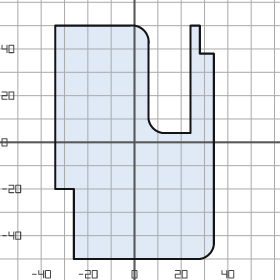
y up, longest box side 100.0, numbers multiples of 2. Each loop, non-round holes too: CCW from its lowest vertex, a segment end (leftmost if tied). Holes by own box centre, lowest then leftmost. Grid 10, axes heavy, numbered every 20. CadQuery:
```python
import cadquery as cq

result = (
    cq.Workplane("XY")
    .moveTo(-26.0, -50.0)
    .lineTo(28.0, -50.0)
    .threePointArc((32.0, -48.0), (34.0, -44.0))
    .lineTo(34.0, 38.0)
    .lineTo(28.0, 38.0)
    .lineTo(28.0, 50.0)
    .lineTo(24.0, 50.0)
    .lineTo(24.0, 4.0)
    .lineTo(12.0, 4.0)
    .threePointArc((8.0, 6.0), (6.0, 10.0))
    .lineTo(6.0, 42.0)
    .threePointArc((4.0, 48.0), (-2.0, 50.0))
    .lineTo(-34.0, 50.0)
    .lineTo(-34.0, -20.0)
    .lineTo(-26.0, -20.0)
    .close()
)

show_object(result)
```